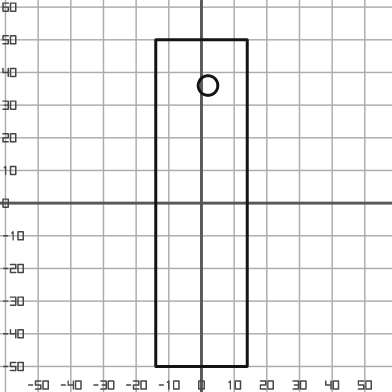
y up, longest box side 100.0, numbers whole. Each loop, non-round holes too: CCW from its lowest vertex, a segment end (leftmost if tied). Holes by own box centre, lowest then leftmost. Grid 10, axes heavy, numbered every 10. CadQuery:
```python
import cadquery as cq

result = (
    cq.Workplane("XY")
    .moveTo(-14.0, -50.0)
    .lineTo(14.0, -50.0)
    .lineTo(14.0, 50.0)
    .lineTo(-14.0, 50.0)
    .close()
    .moveTo(2.0, 36.0)
    .circle(3.0)
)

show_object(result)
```